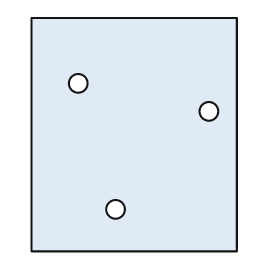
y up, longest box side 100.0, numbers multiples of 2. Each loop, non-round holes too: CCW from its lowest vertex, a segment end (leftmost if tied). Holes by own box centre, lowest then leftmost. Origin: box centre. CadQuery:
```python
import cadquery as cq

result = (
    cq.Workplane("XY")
    .moveTo(-44.0, -50.0)
    .lineTo(44.0, -50.0)
    .lineTo(44.0, 50.0)
    .lineTo(-44.0, 50.0)
    .close()
    .moveTo(-8.0, -32.0)
    .circle(4.0)
    .moveTo(32.0, 10.0)
    .circle(4.0)
    .moveTo(-24.0, 22.0)
    .circle(4.0)
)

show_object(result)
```